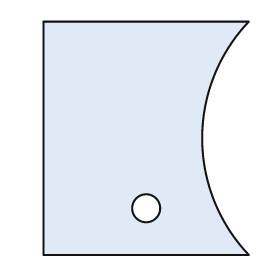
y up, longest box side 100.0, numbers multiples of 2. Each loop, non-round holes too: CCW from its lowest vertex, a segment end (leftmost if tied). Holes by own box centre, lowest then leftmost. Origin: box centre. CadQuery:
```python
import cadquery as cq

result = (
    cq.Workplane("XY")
    .moveTo(-44.0, -50.0)
    .lineTo(44.0, -50.0)
    .threePointArc((24.0, 0.0), (44.0, 50.0))
    .lineTo(-44.0, 50.0)
    .close()
    .moveTo(0.0, -30.0)
    .circle(6.0)
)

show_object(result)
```